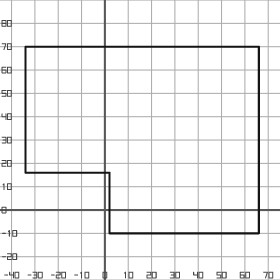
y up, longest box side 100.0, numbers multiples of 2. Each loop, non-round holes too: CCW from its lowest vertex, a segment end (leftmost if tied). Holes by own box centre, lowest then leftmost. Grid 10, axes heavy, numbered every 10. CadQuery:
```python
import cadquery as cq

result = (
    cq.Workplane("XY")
    .moveTo(2.0, -10.0)
    .lineTo(66.0, -10.0)
    .lineTo(66.0, 70.0)
    .lineTo(-34.0, 70.0)
    .lineTo(-34.0, 16.0)
    .lineTo(2.0, 16.0)
    .close()
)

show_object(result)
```